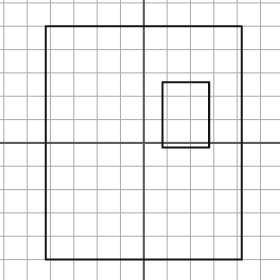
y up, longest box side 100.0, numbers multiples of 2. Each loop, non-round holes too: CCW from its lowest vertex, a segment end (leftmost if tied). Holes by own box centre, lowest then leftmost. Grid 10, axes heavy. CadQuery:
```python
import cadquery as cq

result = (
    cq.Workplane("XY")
    .moveTo(-42.0, -50.0)
    .lineTo(42.0, -50.0)
    .lineTo(42.0, 50.0)
    .lineTo(-42.0, 50.0)
    .close()
    .moveTo(8.0, -2.0)
    .lineTo(28.0, -2.0)
    .lineTo(28.0, 26.0)
    .lineTo(8.0, 26.0)
    .close()
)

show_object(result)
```